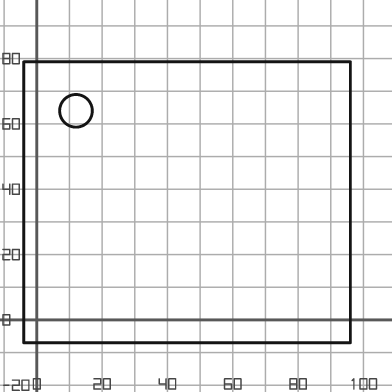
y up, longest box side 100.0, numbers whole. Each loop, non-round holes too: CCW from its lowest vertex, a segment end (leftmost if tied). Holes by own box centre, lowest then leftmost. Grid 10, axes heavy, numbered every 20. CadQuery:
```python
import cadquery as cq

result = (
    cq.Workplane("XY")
    .moveTo(-4.0, -7.0)
    .lineTo(96.0, -7.0)
    .lineTo(96.0, 79.0)
    .lineTo(-4.0, 79.0)
    .close()
    .moveTo(12.0, 64.0)
    .circle(5.0)
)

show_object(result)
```